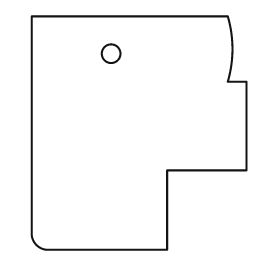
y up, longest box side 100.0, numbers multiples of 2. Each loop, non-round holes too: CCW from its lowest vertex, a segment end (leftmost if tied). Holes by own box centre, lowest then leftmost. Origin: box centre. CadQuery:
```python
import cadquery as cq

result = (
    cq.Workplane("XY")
    .moveTo(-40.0, -50.0)
    .lineTo(12.0, -50.0)
    .lineTo(12.0, -16.0)
    .lineTo(46.0, -16.0)
    .lineTo(46.0, 22.0)
    .lineTo(38.0, 22.0)
    .threePointArc((40.0, 36.0), (38.0, 50.0))
    .lineTo(-46.0, 50.0)
    .lineTo(-46.0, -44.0)
    .threePointArc((-44.0, -48.0), (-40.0, -50.0))
    .close()
    .moveTo(-12.0, 34.0)
    .circle(4.0)
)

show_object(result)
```